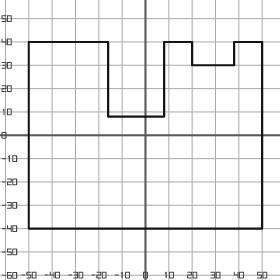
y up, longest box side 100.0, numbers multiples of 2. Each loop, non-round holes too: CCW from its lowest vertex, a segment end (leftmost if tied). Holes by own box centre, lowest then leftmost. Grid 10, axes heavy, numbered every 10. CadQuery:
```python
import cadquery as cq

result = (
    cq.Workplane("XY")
    .moveTo(-50.0, -40.0)
    .lineTo(50.0, -40.0)
    .lineTo(50.0, 40.0)
    .lineTo(38.0, 40.0)
    .lineTo(38.0, 30.0)
    .lineTo(20.0, 30.0)
    .lineTo(20.0, 40.0)
    .lineTo(8.0, 40.0)
    .lineTo(8.0, 8.0)
    .lineTo(-16.0, 8.0)
    .lineTo(-16.0, 40.0)
    .lineTo(-50.0, 40.0)
    .close()
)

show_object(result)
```